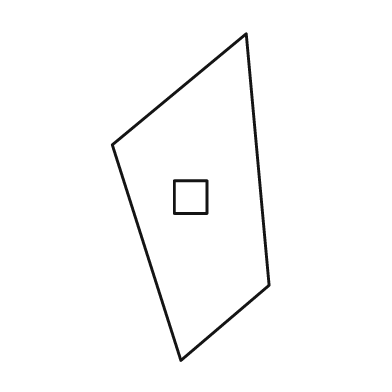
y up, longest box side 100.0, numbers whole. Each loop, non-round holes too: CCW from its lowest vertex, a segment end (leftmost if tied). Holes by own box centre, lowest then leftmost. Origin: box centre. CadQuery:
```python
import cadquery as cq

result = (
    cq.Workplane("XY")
    .moveTo(-3.0, -50.0)
    .lineTo(24.0, -27.0)
    .lineTo(17.0, 50.0)
    .lineTo(-24.0, 16.0)
    .close()
    .moveTo(-5.0, -5.0)
    .lineTo(5.0, -5.0)
    .lineTo(5.0, 5.0)
    .lineTo(-5.0, 5.0)
    .close()
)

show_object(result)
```